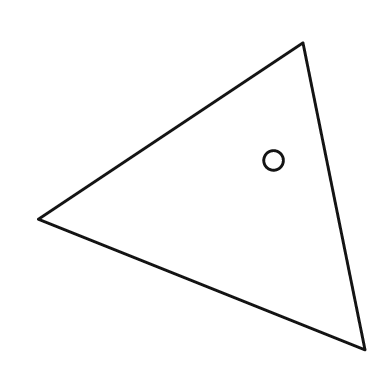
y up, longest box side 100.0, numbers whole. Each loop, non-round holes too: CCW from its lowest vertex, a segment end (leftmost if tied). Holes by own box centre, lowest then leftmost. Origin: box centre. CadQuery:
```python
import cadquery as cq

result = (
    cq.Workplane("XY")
    .moveTo(50.0, -47.0)
    .lineTo(31.0, 47.0)
    .lineTo(-50.0, -7.0)
    .close()
    .moveTo(22.0, 11.0)
    .circle(3.0)
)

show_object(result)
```